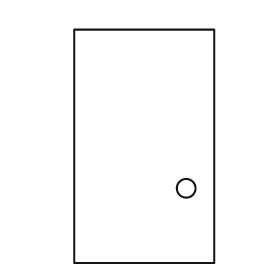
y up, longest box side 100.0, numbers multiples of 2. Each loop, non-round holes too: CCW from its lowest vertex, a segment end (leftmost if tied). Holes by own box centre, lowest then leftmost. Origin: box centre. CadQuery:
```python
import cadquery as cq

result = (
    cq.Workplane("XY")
    .moveTo(-30.0, -50.0)
    .lineTo(30.0, -50.0)
    .lineTo(30.0, 50.0)
    .lineTo(-30.0, 50.0)
    .close()
    .moveTo(18.0, -18.0)
    .circle(4.0)
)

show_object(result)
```